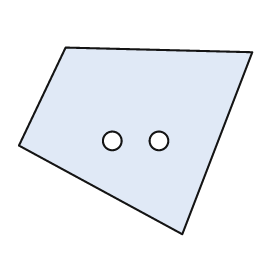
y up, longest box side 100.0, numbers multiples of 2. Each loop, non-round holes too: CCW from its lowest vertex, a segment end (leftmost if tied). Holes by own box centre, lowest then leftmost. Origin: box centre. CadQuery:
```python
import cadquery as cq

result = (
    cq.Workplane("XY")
    .moveTo(20.0, -40.0)
    .lineTo(50.0, 38.0)
    .lineTo(-30.0, 40.0)
    .lineTo(-50.0, -2.0)
    .close()
    .moveTo(-10.0, 0.0)
    .circle(4.0)
    .moveTo(10.0, 0.0)
    .circle(4.0)
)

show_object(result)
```